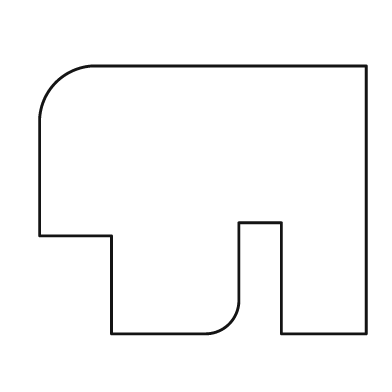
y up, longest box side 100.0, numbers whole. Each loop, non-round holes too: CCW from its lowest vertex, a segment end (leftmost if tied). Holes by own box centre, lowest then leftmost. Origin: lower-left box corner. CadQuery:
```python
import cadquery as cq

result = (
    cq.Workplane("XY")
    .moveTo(22.0, 0.0)
    .lineTo(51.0, 0.0)
    .threePointArc((58.0, 3.0), (61.0, 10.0))
    .lineTo(61.0, 34.0)
    .lineTo(74.0, 34.0)
    .lineTo(74.0, 0.0)
    .lineTo(100.0, 0.0)
    .lineTo(100.0, 82.0)
    .lineTo(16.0, 82.0)
    .threePointArc((5.0, 77.0), (0.0, 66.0))
    .lineTo(0.0, 30.0)
    .lineTo(22.0, 30.0)
    .close()
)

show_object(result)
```